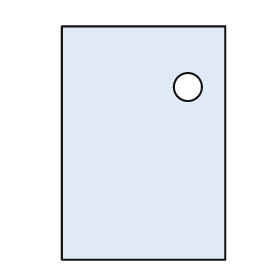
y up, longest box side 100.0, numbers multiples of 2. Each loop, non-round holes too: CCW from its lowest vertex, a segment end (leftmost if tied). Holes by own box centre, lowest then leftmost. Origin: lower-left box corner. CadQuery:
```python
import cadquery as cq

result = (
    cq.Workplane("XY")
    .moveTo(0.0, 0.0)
    .lineTo(70.0, 0.0)
    .lineTo(70.0, 100.0)
    .lineTo(0.0, 100.0)
    .close()
    .moveTo(54.0, 74.0)
    .circle(6.0)
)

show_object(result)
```